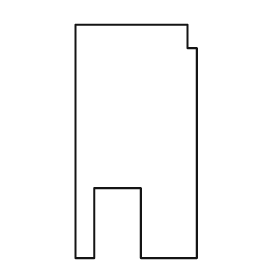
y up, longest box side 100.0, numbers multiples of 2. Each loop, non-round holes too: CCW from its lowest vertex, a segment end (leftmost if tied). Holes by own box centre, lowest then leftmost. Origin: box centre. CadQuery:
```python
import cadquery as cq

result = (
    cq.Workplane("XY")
    .moveTo(-26.0, -50.0)
    .lineTo(-18.0, -50.0)
    .lineTo(-18.0, -20.0)
    .lineTo(2.0, -20.0)
    .lineTo(2.0, -50.0)
    .lineTo(26.0, -50.0)
    .lineTo(26.0, 40.0)
    .lineTo(22.0, 40.0)
    .lineTo(22.0, 50.0)
    .lineTo(-26.0, 50.0)
    .close()
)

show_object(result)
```